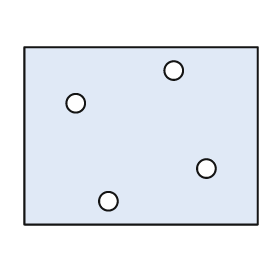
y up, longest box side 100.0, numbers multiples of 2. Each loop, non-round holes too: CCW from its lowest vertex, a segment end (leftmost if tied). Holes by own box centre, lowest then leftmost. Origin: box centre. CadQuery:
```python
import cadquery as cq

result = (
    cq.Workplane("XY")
    .moveTo(-50.0, -38.0)
    .lineTo(50.0, -38.0)
    .lineTo(50.0, 38.0)
    .lineTo(-50.0, 38.0)
    .close()
    .moveTo(-14.0, -28.0)
    .circle(4.0)
    .moveTo(28.0, -14.0)
    .circle(4.0)
    .moveTo(-28.0, 14.0)
    .circle(4.0)
    .moveTo(14.0, 28.0)
    .circle(4.0)
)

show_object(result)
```